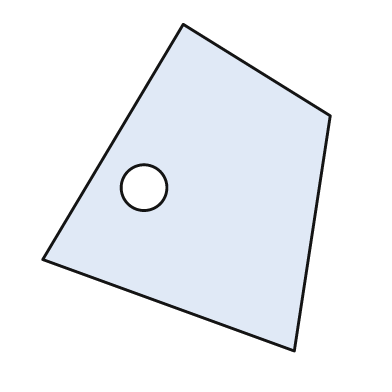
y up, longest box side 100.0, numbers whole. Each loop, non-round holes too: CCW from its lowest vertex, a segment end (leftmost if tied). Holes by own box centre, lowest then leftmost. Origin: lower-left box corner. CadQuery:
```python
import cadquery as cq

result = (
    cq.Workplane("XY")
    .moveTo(77.0, 0.0)
    .lineTo(88.0, 72.0)
    .lineTo(43.0, 100.0)
    .lineTo(0.0, 28.0)
    .close()
    .moveTo(31.0, 50.0)
    .circle(7.0)
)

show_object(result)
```